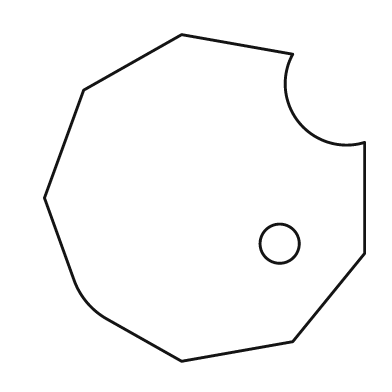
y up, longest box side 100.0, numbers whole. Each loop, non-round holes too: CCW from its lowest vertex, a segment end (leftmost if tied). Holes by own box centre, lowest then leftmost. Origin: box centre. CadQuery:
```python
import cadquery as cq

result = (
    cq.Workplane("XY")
    .moveTo(-7.0, -50.0)
    .lineTo(27.0, -44.0)
    .lineTo(49.0, -17.0)
    .lineTo(49.0, 17.0)
    .threePointArc((29.0, 23.0), (27.0, 44.0))
    .lineTo(-7.0, 50.0)
    .lineTo(-37.0, 33.0)
    .lineTo(-49.0, 0.0)
    .lineTo(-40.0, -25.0)
    .threePointArc((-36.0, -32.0), (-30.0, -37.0))
    .close()
    .moveTo(23.0, -14.0)
    .circle(6.0)
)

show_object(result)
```